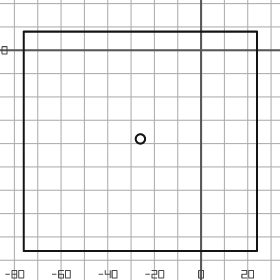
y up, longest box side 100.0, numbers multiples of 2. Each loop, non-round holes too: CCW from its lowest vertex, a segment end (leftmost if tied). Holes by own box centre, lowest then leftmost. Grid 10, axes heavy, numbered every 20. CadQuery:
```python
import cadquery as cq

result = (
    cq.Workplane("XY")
    .moveTo(-76.0, -86.0)
    .lineTo(24.0, -86.0)
    .lineTo(24.0, 8.0)
    .lineTo(-76.0, 8.0)
    .close()
    .moveTo(-26.0, -38.0)
    .circle(2.0)
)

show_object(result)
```